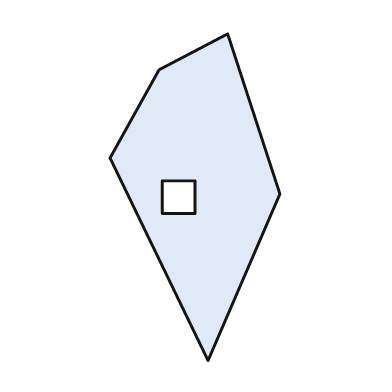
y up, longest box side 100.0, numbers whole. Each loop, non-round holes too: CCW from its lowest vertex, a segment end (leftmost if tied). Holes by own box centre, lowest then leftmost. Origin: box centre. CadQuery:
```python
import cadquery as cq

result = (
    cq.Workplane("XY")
    .moveTo(4.0, -50.0)
    .lineTo(26.0, 1.0)
    .lineTo(10.0, 50.0)
    .lineTo(-11.0, 39.0)
    .lineTo(-26.0, 12.0)
    .close()
    .moveTo(-10.0, -5.0)
    .lineTo(0.0, -5.0)
    .lineTo(0.0, 5.0)
    .lineTo(-10.0, 5.0)
    .close()
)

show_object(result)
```